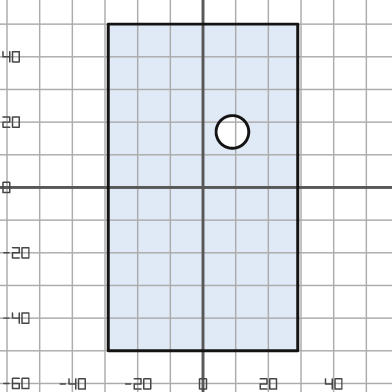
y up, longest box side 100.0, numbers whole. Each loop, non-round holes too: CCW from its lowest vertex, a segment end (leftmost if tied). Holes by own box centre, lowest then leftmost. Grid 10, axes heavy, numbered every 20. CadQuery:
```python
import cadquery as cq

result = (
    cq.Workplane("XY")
    .moveTo(-29.0, -50.0)
    .lineTo(29.0, -50.0)
    .lineTo(29.0, 50.0)
    .lineTo(-29.0, 50.0)
    .close()
    .moveTo(9.0, 17.0)
    .circle(5.0)
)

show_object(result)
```